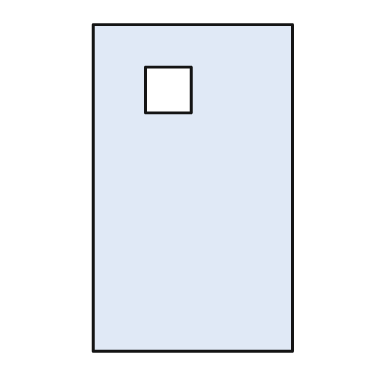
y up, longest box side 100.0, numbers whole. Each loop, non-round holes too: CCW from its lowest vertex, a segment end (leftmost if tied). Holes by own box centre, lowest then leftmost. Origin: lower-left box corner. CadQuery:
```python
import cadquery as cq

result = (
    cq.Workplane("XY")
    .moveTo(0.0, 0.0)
    .lineTo(61.0, 0.0)
    .lineTo(61.0, 100.0)
    .lineTo(0.0, 100.0)
    .close()
    .moveTo(16.0, 73.0)
    .lineTo(30.0, 73.0)
    .lineTo(30.0, 87.0)
    .lineTo(16.0, 87.0)
    .close()
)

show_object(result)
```